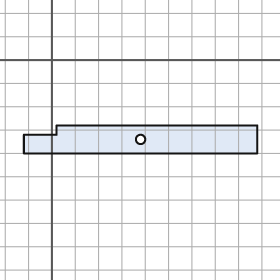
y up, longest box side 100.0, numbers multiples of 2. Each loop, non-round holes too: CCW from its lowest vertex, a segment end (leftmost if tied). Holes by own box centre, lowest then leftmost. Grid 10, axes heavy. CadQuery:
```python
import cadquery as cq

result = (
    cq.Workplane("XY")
    .moveTo(-12.0, -40.0)
    .lineTo(88.0, -40.0)
    .lineTo(88.0, -28.0)
    .lineTo(2.0, -28.0)
    .lineTo(2.0, -32.0)
    .lineTo(-12.0, -32.0)
    .close()
    .moveTo(38.0, -34.0)
    .circle(2.0)
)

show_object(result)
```